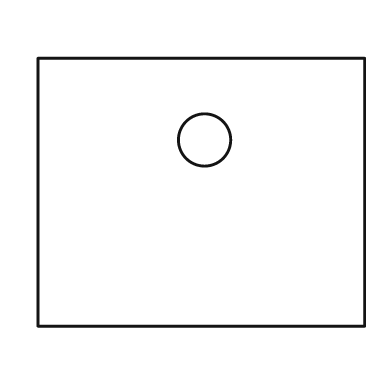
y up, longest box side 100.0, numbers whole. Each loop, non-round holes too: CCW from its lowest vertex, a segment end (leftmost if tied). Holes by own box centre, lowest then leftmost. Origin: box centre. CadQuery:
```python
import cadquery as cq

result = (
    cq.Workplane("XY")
    .moveTo(-50.0, -41.0)
    .lineTo(50.0, -41.0)
    .lineTo(50.0, 41.0)
    .lineTo(-50.0, 41.0)
    .close()
    .moveTo(1.0, 16.0)
    .circle(8.0)
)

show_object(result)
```